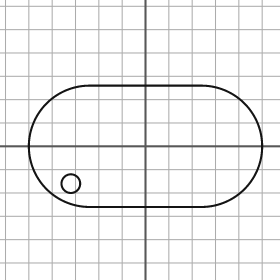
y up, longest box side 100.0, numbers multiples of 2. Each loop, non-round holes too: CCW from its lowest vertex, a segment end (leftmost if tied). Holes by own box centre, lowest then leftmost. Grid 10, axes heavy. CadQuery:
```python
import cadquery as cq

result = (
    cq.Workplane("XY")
    .moveTo(-24.0, -26.0)
    .lineTo(24.0, -26.0)
    .threePointArc((50.0, 0.0), (24.0, 26.0))
    .lineTo(-24.0, 26.0)
    .threePointArc((-50.0, 0.0), (-24.0, -26.0))
    .close()
    .moveTo(-32.0, -16.0)
    .circle(4.0)
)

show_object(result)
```